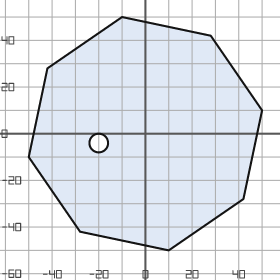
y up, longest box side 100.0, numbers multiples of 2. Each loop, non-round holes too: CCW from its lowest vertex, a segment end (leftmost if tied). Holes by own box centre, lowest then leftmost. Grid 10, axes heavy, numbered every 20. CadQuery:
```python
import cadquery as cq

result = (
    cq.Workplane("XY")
    .moveTo(10.0, -50.0)
    .lineTo(42.0, -28.0)
    .lineTo(50.0, 10.0)
    .lineTo(28.0, 42.0)
    .lineTo(-10.0, 50.0)
    .lineTo(-42.0, 28.0)
    .lineTo(-50.0, -10.0)
    .lineTo(-28.0, -42.0)
    .close()
    .moveTo(-20.0, -4.0)
    .circle(4.0)
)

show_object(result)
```